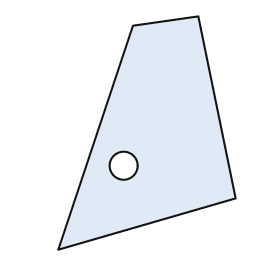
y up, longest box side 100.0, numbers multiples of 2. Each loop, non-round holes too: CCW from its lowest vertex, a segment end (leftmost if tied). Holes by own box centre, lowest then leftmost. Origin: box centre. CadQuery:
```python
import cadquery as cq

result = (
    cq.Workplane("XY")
    .moveTo(-38.0, -50.0)
    .lineTo(38.0, -28.0)
    .lineTo(22.0, 50.0)
    .lineTo(-6.0, 46.0)
    .close()
    .moveTo(-10.0, -14.0)
    .circle(6.0)
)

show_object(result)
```